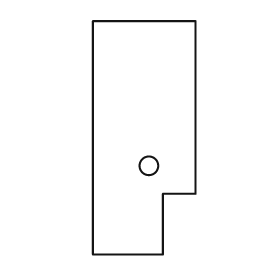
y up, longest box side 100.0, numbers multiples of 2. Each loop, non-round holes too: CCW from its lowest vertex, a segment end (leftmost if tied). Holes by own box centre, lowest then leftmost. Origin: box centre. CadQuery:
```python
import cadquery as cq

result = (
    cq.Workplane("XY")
    .moveTo(-22.0, -50.0)
    .lineTo(8.0, -50.0)
    .lineTo(8.0, -24.0)
    .lineTo(22.0, -24.0)
    .lineTo(22.0, 50.0)
    .lineTo(-22.0, 50.0)
    .close()
    .moveTo(2.0, -12.0)
    .circle(4.0)
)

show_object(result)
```